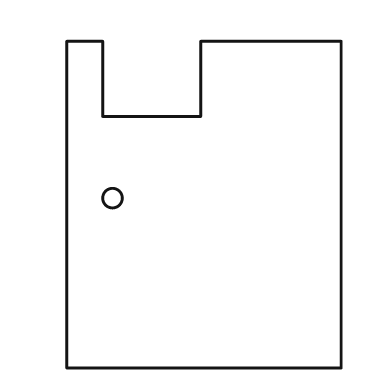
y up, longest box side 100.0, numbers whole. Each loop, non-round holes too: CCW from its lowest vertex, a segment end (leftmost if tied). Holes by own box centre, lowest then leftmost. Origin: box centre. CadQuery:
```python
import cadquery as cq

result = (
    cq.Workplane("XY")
    .moveTo(-42.0, -50.0)
    .lineTo(42.0, -50.0)
    .lineTo(42.0, 50.0)
    .lineTo(-1.0, 50.0)
    .lineTo(-1.0, 27.0)
    .lineTo(-31.0, 27.0)
    .lineTo(-31.0, 50.0)
    .lineTo(-42.0, 50.0)
    .close()
    .moveTo(-28.0, 2.0)
    .circle(3.0)
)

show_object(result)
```